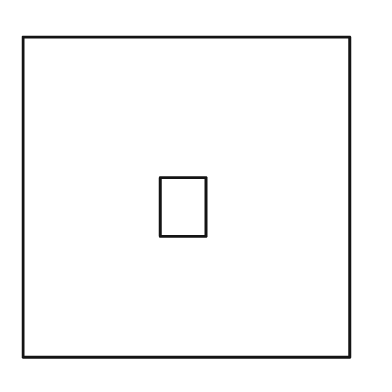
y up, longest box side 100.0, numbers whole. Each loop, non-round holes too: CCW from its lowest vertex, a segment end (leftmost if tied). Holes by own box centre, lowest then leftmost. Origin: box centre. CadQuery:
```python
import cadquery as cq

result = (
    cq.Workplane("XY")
    .moveTo(-50.0, -49.0)
    .lineTo(50.0, -49.0)
    .lineTo(50.0, 49.0)
    .lineTo(-50.0, 49.0)
    .close()
    .moveTo(-8.0, -12.0)
    .lineTo(6.0, -12.0)
    .lineTo(6.0, 6.0)
    .lineTo(-8.0, 6.0)
    .close()
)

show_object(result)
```